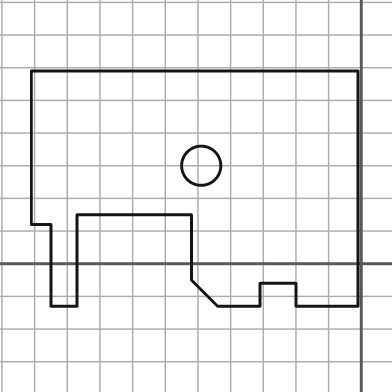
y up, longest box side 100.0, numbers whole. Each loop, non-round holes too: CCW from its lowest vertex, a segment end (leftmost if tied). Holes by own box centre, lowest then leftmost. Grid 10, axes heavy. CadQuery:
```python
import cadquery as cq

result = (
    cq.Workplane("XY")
    .moveTo(-95.0, -13.0)
    .lineTo(-87.0, -13.0)
    .lineTo(-87.0, 15.0)
    .lineTo(-52.0, 15.0)
    .lineTo(-52.0, -5.0)
    .lineTo(-44.0, -13.0)
    .lineTo(-31.0, -13.0)
    .lineTo(-31.0, -6.0)
    .lineTo(-20.0, -6.0)
    .lineTo(-20.0, -13.0)
    .lineTo(-1.0, -13.0)
    .lineTo(-1.0, 59.0)
    .lineTo(-101.0, 59.0)
    .lineTo(-101.0, 12.0)
    .lineTo(-95.0, 12.0)
    .close()
    .moveTo(-49.0, 30.0)
    .circle(6.0)
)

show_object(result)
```